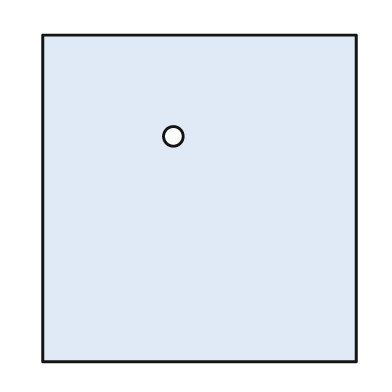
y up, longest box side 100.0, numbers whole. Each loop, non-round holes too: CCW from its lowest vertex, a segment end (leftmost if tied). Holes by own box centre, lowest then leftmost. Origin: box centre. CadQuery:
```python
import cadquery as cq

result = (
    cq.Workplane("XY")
    .moveTo(-48.0, -50.0)
    .lineTo(48.0, -50.0)
    .lineTo(48.0, 50.0)
    .lineTo(-48.0, 50.0)
    .close()
    .moveTo(-8.0, 19.0)
    .circle(3.0)
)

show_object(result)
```